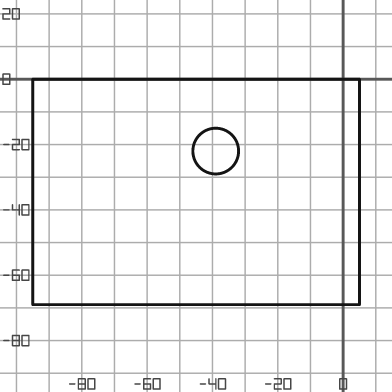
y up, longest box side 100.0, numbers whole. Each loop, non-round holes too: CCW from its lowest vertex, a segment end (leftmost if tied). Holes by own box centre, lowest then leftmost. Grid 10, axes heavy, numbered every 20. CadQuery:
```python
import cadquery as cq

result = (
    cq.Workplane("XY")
    .moveTo(-95.0, -69.0)
    .lineTo(5.0, -69.0)
    .lineTo(5.0, 0.0)
    .lineTo(-95.0, 0.0)
    .close()
    .moveTo(-39.0, -22.0)
    .circle(7.0)
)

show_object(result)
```